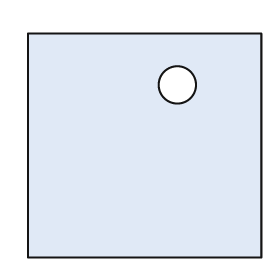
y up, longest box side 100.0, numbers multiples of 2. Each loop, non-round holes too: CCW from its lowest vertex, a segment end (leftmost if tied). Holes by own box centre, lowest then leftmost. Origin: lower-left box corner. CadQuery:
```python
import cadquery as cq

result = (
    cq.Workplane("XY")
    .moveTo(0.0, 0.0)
    .lineTo(100.0, 0.0)
    .lineTo(100.0, 96.0)
    .lineTo(0.0, 96.0)
    .close()
    .moveTo(64.0, 74.0)
    .circle(8.0)
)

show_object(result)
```